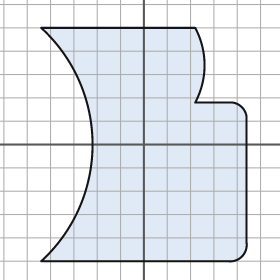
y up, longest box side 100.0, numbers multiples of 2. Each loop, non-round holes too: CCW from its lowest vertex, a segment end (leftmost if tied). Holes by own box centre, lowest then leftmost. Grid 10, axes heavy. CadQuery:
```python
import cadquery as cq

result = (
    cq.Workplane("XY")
    .moveTo(-44.0, -50.0)
    .lineTo(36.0, -50.0)
    .threePointArc((42.0, -48.0), (44.0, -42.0))
    .lineTo(44.0, 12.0)
    .threePointArc((42.0, 16.0), (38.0, 18.0))
    .lineTo(22.0, 18.0)
    .threePointArc((26.0, 34.0), (22.0, 50.0))
    .lineTo(-44.0, 50.0)
    .threePointArc((-22.0, 0.0), (-44.0, -50.0))
    .close()
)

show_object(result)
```